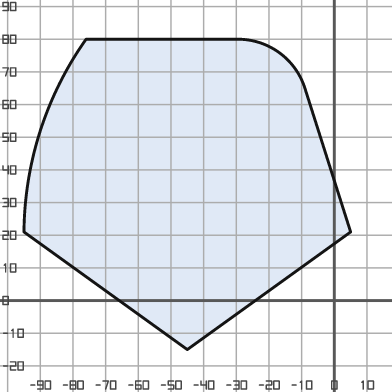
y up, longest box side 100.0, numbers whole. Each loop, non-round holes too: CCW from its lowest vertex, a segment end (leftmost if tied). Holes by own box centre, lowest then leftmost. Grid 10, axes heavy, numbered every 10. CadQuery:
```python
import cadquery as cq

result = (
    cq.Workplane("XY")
    .moveTo(-45.0, -15.0)
    .lineTo(5.0, 21.0)
    .lineTo(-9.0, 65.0)
    .threePointArc((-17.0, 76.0), (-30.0, 80.0))
    .lineTo(-76.0, 80.0)
    .threePointArc((-90.0, 52.0), (-95.0, 21.0))
    .close()
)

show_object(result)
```